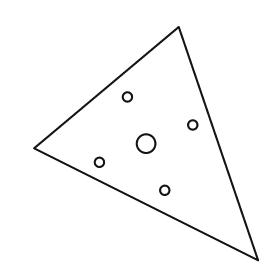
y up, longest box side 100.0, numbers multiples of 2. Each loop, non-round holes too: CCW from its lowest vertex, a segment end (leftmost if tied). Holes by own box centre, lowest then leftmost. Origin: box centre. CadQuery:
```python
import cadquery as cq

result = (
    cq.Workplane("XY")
    .moveTo(48.0, -50.0)
    .lineTo(14.0, 50.0)
    .lineTo(-48.0, -2.0)
    .close()
    .moveTo(8.0, -20.0)
    .circle(2.0)
    .moveTo(-20.0, -8.0)
    .circle(2.0)
    .moveTo(0.0, 0.0)
    .circle(4.0)
    .moveTo(20.0, 8.0)
    .circle(2.0)
    .moveTo(-8.0, 20.0)
    .circle(2.0)
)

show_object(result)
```